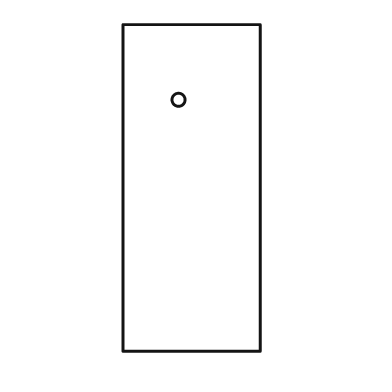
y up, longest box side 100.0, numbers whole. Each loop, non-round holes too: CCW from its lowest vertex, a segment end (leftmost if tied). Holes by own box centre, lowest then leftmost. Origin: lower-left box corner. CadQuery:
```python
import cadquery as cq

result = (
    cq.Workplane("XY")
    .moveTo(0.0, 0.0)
    .lineTo(42.0, 0.0)
    .lineTo(42.0, 100.0)
    .lineTo(0.0, 100.0)
    .close()
    .moveTo(17.0, 77.0)
    .circle(2.0)
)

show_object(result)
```